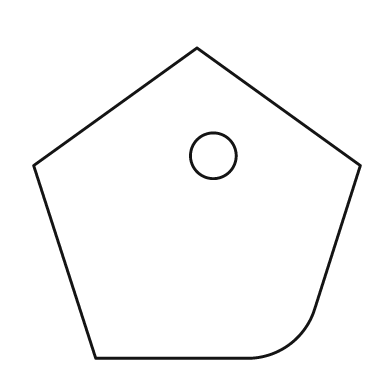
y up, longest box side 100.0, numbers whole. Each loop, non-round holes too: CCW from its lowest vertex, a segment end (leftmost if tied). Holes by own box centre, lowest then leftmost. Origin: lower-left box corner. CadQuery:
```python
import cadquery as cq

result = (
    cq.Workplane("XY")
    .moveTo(19.0, 0.0)
    .lineTo(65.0, 0.0)
    .threePointArc((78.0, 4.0), (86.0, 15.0))
    .lineTo(100.0, 59.0)
    .lineTo(50.0, 95.0)
    .lineTo(0.0, 59.0)
    .close()
    .moveTo(55.0, 62.0)
    .circle(7.0)
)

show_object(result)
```